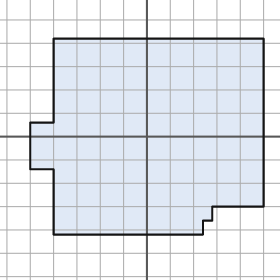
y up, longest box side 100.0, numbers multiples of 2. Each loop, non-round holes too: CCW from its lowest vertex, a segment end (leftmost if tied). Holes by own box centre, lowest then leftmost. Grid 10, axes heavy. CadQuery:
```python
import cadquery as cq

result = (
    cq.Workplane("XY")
    .moveTo(-40.0, -42.0)
    .lineTo(24.0, -42.0)
    .lineTo(24.0, -36.0)
    .lineTo(28.0, -36.0)
    .lineTo(28.0, -30.0)
    .lineTo(50.0, -30.0)
    .lineTo(50.0, 42.0)
    .lineTo(-40.0, 42.0)
    .lineTo(-40.0, 6.0)
    .lineTo(-50.0, 6.0)
    .lineTo(-50.0, -14.0)
    .lineTo(-40.0, -14.0)
    .close()
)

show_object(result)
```